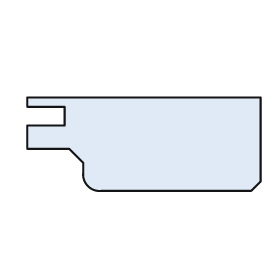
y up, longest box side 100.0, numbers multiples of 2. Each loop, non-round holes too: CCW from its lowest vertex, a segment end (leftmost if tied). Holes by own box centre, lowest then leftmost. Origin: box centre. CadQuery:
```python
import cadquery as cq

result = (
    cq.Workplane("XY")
    .moveTo(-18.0, -20.0)
    .lineTo(46.0, -20.0)
    .lineTo(50.0, -16.0)
    .lineTo(50.0, 20.0)
    .lineTo(-50.0, 20.0)
    .lineTo(-50.0, 16.0)
    .lineTo(-34.0, 16.0)
    .lineTo(-34.0, 8.0)
    .lineTo(-50.0, 8.0)
    .lineTo(-50.0, -2.0)
    .lineTo(-32.0, -2.0)
    .lineTo(-26.0, -8.0)
    .lineTo(-26.0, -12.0)
    .threePointArc((-24.0, -18.0), (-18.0, -20.0))
    .close()
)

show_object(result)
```